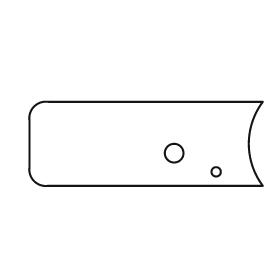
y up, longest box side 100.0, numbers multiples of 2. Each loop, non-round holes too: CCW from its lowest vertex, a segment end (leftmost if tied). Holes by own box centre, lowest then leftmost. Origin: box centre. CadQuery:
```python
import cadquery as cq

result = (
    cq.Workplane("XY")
    .moveTo(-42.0, -18.0)
    .lineTo(50.0, -18.0)
    .threePointArc((44.0, 0.0), (50.0, 18.0))
    .lineTo(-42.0, 18.0)
    .threePointArc((-48.0, 16.0), (-50.0, 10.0))
    .lineTo(-50.0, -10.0)
    .threePointArc((-48.0, -16.0), (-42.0, -18.0))
    .close()
    .moveTo(30.0, -12.0)
    .circle(2.0)
    .moveTo(12.0, -4.0)
    .circle(4.0)
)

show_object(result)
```